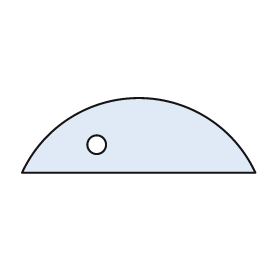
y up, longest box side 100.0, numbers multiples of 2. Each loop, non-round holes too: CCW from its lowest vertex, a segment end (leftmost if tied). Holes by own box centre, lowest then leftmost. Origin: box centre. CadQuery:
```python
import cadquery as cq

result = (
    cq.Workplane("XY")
    .moveTo(-50.0, -16.0)
    .lineTo(50.0, -16.0)
    .threePointArc((0.0, 16.0), (-50.0, -16.0))
    .close()
    .moveTo(-18.0, -4.0)
    .circle(4.0)
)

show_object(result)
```